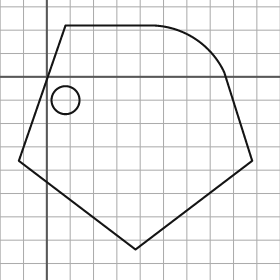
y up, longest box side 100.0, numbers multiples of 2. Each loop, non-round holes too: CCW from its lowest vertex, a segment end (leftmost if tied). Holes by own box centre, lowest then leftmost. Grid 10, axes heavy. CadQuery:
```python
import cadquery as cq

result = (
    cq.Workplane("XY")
    .moveTo(38.0, -74.0)
    .lineTo(88.0, -36.0)
    .lineTo(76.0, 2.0)
    .threePointArc((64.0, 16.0), (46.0, 22.0))
    .lineTo(8.0, 22.0)
    .lineTo(-12.0, -36.0)
    .close()
    .moveTo(8.0, -10.0)
    .circle(6.0)
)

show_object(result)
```